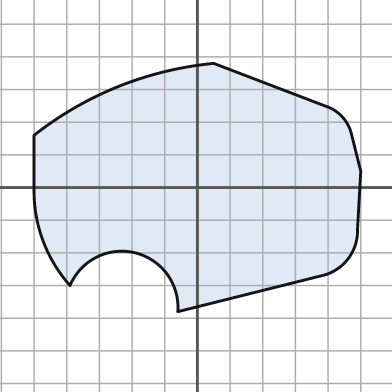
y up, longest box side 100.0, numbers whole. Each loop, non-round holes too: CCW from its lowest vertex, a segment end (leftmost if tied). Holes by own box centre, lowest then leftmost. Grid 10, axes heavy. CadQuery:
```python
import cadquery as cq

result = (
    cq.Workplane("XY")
    .moveTo(-6.0, -38.0)
    .lineTo(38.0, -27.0)
    .threePointArc((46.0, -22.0), (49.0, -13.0))
    .lineTo(50.0, 5.0)
    .lineTo(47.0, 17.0)
    .threePointArc((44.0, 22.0), (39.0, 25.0))
    .lineTo(5.0, 38.0)
    .threePointArc((-24.0, 31.0), (-50.0, 16.0))
    .lineTo(-50.0, -2.0)
    .threePointArc((-47.0, -17.0), (-39.0, -30.0))
    .threePointArc((-19.0, -20.0), (-6.0, -38.0))
    .close()
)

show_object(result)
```